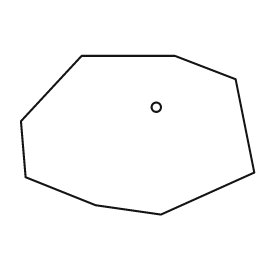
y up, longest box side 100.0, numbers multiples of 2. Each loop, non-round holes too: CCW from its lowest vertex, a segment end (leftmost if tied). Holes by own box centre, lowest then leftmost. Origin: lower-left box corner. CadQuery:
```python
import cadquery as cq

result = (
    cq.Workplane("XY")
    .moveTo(60.0, 0.0)
    .lineTo(100.0, 18.0)
    .lineTo(92.0, 58.0)
    .lineTo(66.0, 68.0)
    .lineTo(26.0, 68.0)
    .lineTo(0.0, 40.0)
    .lineTo(2.0, 16.0)
    .lineTo(32.0, 4.0)
    .close()
    .moveTo(58.0, 46.0)
    .circle(2.0)
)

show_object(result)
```